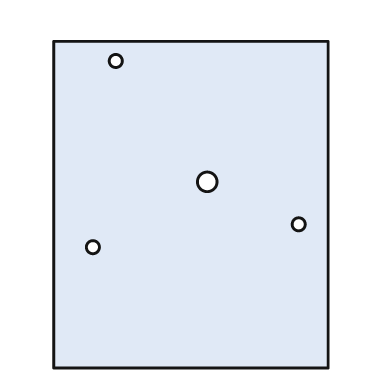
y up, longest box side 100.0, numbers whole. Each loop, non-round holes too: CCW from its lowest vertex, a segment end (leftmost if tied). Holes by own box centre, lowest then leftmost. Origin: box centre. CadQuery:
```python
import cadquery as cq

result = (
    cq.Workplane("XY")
    .moveTo(-42.0, -50.0)
    .lineTo(42.0, -50.0)
    .lineTo(42.0, 50.0)
    .lineTo(-42.0, 50.0)
    .close()
    .moveTo(-30.0, -13.0)
    .circle(2.0)
    .moveTo(33.0, -6.0)
    .circle(2.0)
    .moveTo(5.0, 7.0)
    .circle(3.0)
    .moveTo(-23.0, 44.0)
    .circle(2.0)
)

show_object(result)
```